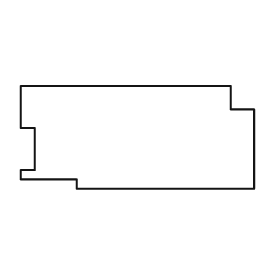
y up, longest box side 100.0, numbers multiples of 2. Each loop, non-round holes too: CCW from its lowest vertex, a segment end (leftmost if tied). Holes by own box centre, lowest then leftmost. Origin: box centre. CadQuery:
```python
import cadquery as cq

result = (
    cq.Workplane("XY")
    .moveTo(-26.0, -22.0)
    .lineTo(50.0, -22.0)
    .lineTo(50.0, 12.0)
    .lineTo(40.0, 12.0)
    .lineTo(40.0, 22.0)
    .lineTo(-50.0, 22.0)
    .lineTo(-50.0, 4.0)
    .lineTo(-44.0, 4.0)
    .lineTo(-44.0, -14.0)
    .lineTo(-50.0, -14.0)
    .lineTo(-50.0, -18.0)
    .lineTo(-26.0, -18.0)
    .close()
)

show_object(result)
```